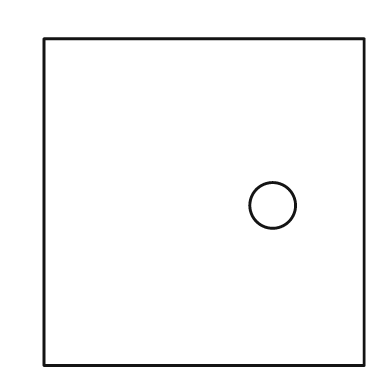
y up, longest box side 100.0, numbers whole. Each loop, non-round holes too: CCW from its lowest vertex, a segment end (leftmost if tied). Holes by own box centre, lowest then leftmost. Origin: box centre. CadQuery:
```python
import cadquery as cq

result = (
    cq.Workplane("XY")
    .moveTo(-49.0, -50.0)
    .lineTo(49.0, -50.0)
    .lineTo(49.0, 50.0)
    .lineTo(-49.0, 50.0)
    .close()
    .moveTo(21.0, -1.0)
    .circle(7.0)
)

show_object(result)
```